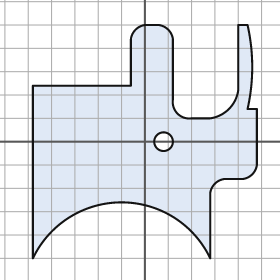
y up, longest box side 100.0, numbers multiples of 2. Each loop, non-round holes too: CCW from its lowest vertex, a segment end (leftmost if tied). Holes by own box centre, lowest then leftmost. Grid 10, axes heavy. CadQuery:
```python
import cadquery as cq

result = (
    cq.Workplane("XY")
    .moveTo(-48.0, -50.0)
    .threePointArc((-10.0, -26.0), (28.0, -50.0))
    .lineTo(28.0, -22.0)
    .threePointArc((30.0, -18.0), (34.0, -16.0))
    .lineTo(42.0, -16.0)
    .threePointArc((46.0, -14.0), (48.0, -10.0))
    .lineTo(48.0, 14.0)
    .lineTo(44.0, 14.0)
    .threePointArc((46.0, 32.0), (44.0, 50.0))
    .lineTo(40.0, 50.0)
    .lineTo(40.0, 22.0)
    .threePointArc((36.0, 14.0), (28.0, 10.0))
    .lineTo(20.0, 10.0)
    .threePointArc((14.0, 12.0), (12.0, 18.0))
    .lineTo(12.0, 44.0)
    .threePointArc((10.0, 48.0), (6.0, 50.0))
    .lineTo(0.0, 50.0)
    .threePointArc((-4.0, 48.0), (-6.0, 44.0))
    .lineTo(-6.0, 24.0)
    .lineTo(-48.0, 24.0)
    .close()
    .moveTo(8.0, 0.0)
    .circle(4.0)
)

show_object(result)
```